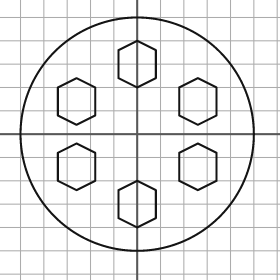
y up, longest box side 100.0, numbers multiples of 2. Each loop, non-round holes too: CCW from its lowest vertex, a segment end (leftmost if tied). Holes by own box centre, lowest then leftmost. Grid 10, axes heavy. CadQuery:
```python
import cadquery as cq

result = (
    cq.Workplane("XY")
    .moveTo(0.0, 0.0)
    .circle(50.0)
    .moveTo(0.0, -40.0)
    .lineTo(8.0, -36.0)
    .lineTo(8.0, -24.0)
    .lineTo(0.0, -20.0)
    .lineTo(-8.0, -24.0)
    .lineTo(-8.0, -36.0)
    .close()
    .moveTo(-26.0, -24.0)
    .lineTo(-18.0, -20.0)
    .lineTo(-18.0, -8.0)
    .lineTo(-26.0, -4.0)
    .lineTo(-34.0, -8.0)
    .lineTo(-34.0, -20.0)
    .close()
    .moveTo(26.0, -24.0)
    .lineTo(34.0, -20.0)
    .lineTo(34.0, -8.0)
    .lineTo(26.0, -4.0)
    .lineTo(18.0, -8.0)
    .lineTo(18.0, -20.0)
    .close()
    .moveTo(-26.0, 4.0)
    .lineTo(-18.0, 8.0)
    .lineTo(-18.0, 20.0)
    .lineTo(-26.0, 24.0)
    .lineTo(-34.0, 20.0)
    .lineTo(-34.0, 8.0)
    .close()
    .moveTo(26.0, 4.0)
    .lineTo(34.0, 8.0)
    .lineTo(34.0, 20.0)
    .lineTo(26.0, 24.0)
    .lineTo(18.0, 20.0)
    .lineTo(18.0, 8.0)
    .close()
    .moveTo(0.0, 20.0)
    .lineTo(8.0, 24.0)
    .lineTo(8.0, 36.0)
    .lineTo(0.0, 40.0)
    .lineTo(-8.0, 36.0)
    .lineTo(-8.0, 24.0)
    .close()
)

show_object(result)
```